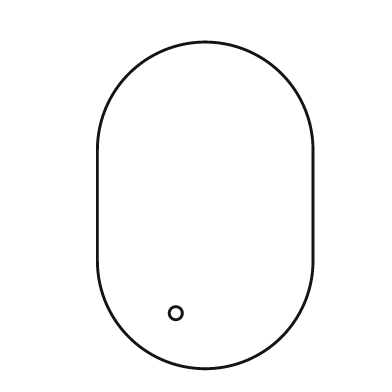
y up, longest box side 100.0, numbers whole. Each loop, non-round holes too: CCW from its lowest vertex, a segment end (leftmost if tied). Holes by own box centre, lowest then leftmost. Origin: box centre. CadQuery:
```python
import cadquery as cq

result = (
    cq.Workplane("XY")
    .moveTo(-33.0, -17.0)
    .threePointArc((0.0, -50.0), (33.0, -17.0))
    .lineTo(33.0, 17.0)
    .threePointArc((0.0, 50.0), (-33.0, 17.0))
    .close()
    .moveTo(-9.0, -33.0)
    .circle(2.0)
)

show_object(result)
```